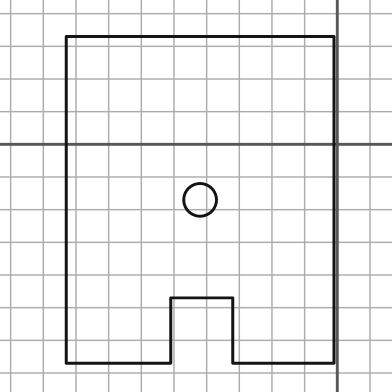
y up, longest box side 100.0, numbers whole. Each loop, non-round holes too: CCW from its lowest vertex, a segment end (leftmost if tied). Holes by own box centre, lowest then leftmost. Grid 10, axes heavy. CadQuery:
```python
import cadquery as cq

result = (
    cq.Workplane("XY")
    .moveTo(-83.0, -67.0)
    .lineTo(-51.0, -67.0)
    .lineTo(-51.0, -47.0)
    .lineTo(-32.0, -47.0)
    .lineTo(-32.0, -67.0)
    .lineTo(-1.0, -67.0)
    .lineTo(-1.0, 33.0)
    .lineTo(-83.0, 33.0)
    .close()
    .moveTo(-42.0, -17.0)
    .circle(5.0)
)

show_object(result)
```